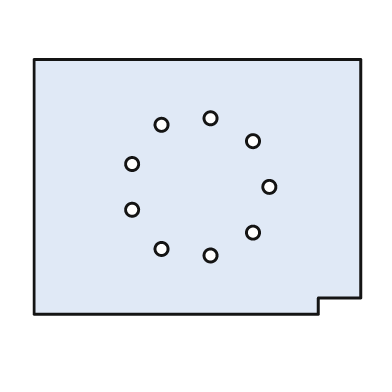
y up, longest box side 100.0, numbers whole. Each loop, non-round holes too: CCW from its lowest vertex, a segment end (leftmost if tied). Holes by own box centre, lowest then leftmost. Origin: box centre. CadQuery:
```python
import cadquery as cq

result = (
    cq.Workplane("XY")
    .moveTo(-50.0, -39.0)
    .lineTo(37.0, -39.0)
    .lineTo(37.0, -34.0)
    .lineTo(50.0, -34.0)
    .lineTo(50.0, 39.0)
    .lineTo(-50.0, 39.0)
    .close()
    .moveTo(4.0, -21.0)
    .circle(2.0)
    .moveTo(-11.0, -19.0)
    .circle(2.0)
    .moveTo(17.0, -14.0)
    .circle(2.0)
    .moveTo(-20.0, -7.0)
    .circle(2.0)
    .moveTo(22.0, 0.0)
    .circle(2.0)
    .moveTo(-20.0, 7.0)
    .circle(2.0)
    .moveTo(17.0, 14.0)
    .circle(2.0)
    .moveTo(-11.0, 19.0)
    .circle(2.0)
    .moveTo(4.0, 21.0)
    .circle(2.0)
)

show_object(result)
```